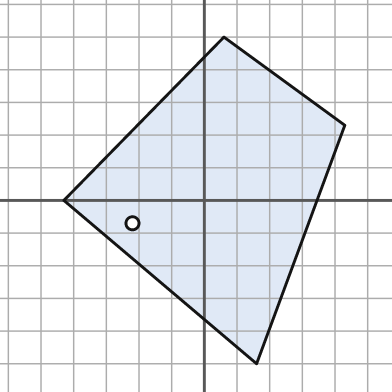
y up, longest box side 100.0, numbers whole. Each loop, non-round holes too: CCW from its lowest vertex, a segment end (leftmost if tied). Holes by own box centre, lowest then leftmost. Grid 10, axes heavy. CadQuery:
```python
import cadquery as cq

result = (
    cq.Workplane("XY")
    .moveTo(16.0, -50.0)
    .lineTo(43.0, 23.0)
    .lineTo(6.0, 50.0)
    .lineTo(-43.0, 0.0)
    .close()
    .moveTo(-22.0, -7.0)
    .circle(2.0)
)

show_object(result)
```